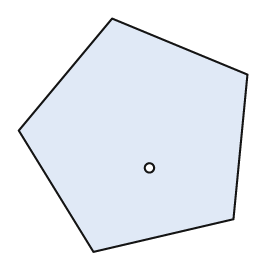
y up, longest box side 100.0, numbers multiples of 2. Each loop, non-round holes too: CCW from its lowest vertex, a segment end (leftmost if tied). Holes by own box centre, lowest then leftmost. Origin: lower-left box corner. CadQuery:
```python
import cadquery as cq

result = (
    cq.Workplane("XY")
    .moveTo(32.0, 0.0)
    .lineTo(92.0, 14.0)
    .lineTo(98.0, 76.0)
    .lineTo(40.0, 100.0)
    .lineTo(0.0, 52.0)
    .close()
    .moveTo(56.0, 36.0)
    .circle(2.0)
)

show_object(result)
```